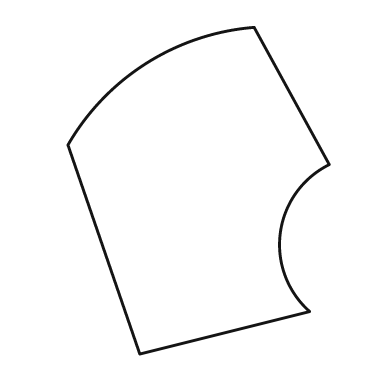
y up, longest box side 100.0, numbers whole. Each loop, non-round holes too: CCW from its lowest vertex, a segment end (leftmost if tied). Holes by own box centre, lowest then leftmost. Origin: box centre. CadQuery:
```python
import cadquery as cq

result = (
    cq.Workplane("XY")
    .moveTo(-18.0, -50.0)
    .lineTo(34.0, -37.0)
    .threePointArc((25.0, -13.0), (40.0, 8.0))
    .lineTo(17.0, 50.0)
    .threePointArc((-16.0, 39.0), (-40.0, 14.0))
    .close()
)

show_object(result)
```